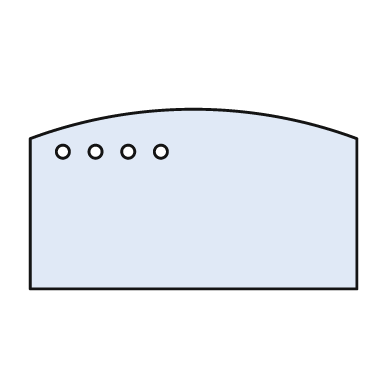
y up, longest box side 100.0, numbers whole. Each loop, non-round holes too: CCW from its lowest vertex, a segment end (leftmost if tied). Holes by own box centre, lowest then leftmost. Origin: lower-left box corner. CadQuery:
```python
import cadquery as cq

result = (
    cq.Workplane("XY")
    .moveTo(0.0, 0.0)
    .lineTo(100.0, 0.0)
    .lineTo(100.0, 46.0)
    .threePointArc((50.0, 55.0), (0.0, 46.0))
    .close()
    .moveTo(10.0, 42.0)
    .circle(2.0)
    .moveTo(20.0, 42.0)
    .circle(2.0)
    .moveTo(30.0, 42.0)
    .circle(2.0)
    .moveTo(40.0, 42.0)
    .circle(2.0)
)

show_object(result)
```